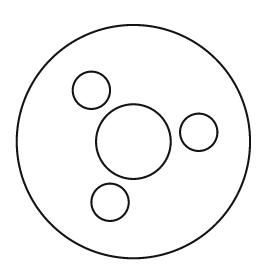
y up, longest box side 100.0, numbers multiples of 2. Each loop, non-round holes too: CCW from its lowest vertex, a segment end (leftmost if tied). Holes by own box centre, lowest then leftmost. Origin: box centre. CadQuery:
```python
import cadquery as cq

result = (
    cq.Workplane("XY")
    .moveTo(0.0, 0.0)
    .circle(50.0)
    .moveTo(-10.0, -26.0)
    .circle(8.0)
    .moveTo(0.0, 0.0)
    .circle(16.0)
    .moveTo(28.0, 4.0)
    .circle(8.0)
    .moveTo(-18.0, 22.0)
    .circle(8.0)
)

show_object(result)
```